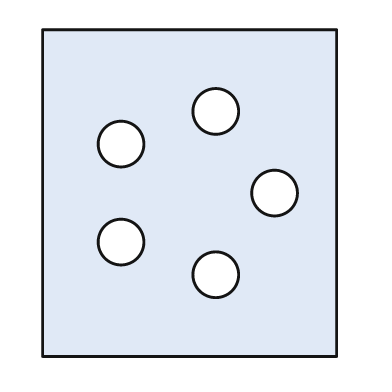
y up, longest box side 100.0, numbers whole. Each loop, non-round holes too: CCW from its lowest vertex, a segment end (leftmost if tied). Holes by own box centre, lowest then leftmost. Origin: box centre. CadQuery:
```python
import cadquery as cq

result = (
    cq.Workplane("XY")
    .moveTo(-45.0, -50.0)
    .lineTo(45.0, -50.0)
    .lineTo(45.0, 50.0)
    .lineTo(-45.0, 50.0)
    .close()
    .moveTo(8.0, -25.0)
    .circle(7.0)
    .moveTo(-21.0, -15.0)
    .circle(7.0)
    .moveTo(26.0, 0.0)
    .circle(7.0)
    .moveTo(-21.0, 15.0)
    .circle(7.0)
    .moveTo(8.0, 25.0)
    .circle(7.0)
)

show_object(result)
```